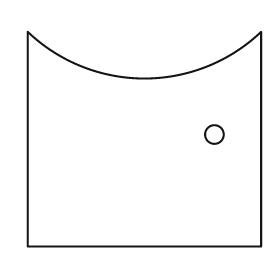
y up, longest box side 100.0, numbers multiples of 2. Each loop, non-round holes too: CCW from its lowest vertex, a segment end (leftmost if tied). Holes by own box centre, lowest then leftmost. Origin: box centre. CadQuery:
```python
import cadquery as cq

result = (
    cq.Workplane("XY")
    .moveTo(-50.0, -46.0)
    .lineTo(50.0, -46.0)
    .lineTo(50.0, 46.0)
    .threePointArc((0.0, 26.0), (-50.0, 46.0))
    .close()
    .moveTo(30.0, 2.0)
    .circle(4.0)
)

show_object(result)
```